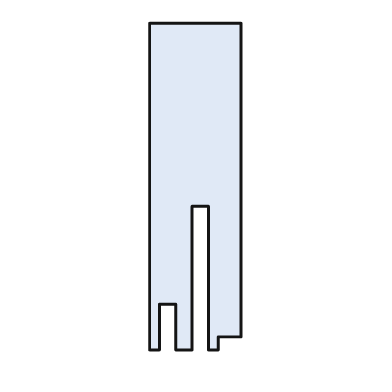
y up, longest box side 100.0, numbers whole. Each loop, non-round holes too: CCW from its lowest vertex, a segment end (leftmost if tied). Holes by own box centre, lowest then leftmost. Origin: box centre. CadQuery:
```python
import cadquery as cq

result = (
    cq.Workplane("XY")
    .moveTo(-14.0, -50.0)
    .lineTo(-11.0, -50.0)
    .lineTo(-11.0, -36.0)
    .lineTo(-6.0, -36.0)
    .lineTo(-6.0, -50.0)
    .lineTo(-1.0, -50.0)
    .lineTo(-1.0, -6.0)
    .lineTo(4.0, -6.0)
    .lineTo(4.0, -50.0)
    .lineTo(7.0, -50.0)
    .lineTo(7.0, -46.0)
    .lineTo(14.0, -46.0)
    .lineTo(14.0, 50.0)
    .lineTo(-14.0, 50.0)
    .close()
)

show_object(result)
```